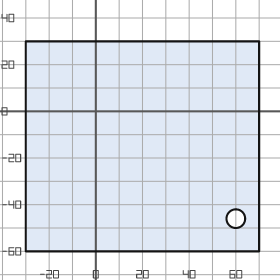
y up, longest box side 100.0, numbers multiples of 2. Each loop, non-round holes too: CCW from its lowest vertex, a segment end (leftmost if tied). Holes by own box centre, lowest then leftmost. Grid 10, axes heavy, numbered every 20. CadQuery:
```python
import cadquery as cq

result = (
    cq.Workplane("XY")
    .moveTo(-30.0, -60.0)
    .lineTo(70.0, -60.0)
    .lineTo(70.0, 30.0)
    .lineTo(-30.0, 30.0)
    .close()
    .moveTo(60.0, -46.0)
    .circle(4.0)
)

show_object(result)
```